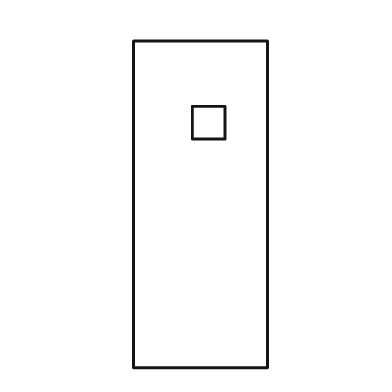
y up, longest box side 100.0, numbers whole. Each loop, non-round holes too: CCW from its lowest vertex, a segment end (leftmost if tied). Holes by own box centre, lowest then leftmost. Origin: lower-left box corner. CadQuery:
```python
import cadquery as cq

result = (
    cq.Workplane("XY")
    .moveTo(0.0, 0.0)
    .lineTo(41.0, 0.0)
    .lineTo(41.0, 100.0)
    .lineTo(0.0, 100.0)
    .close()
    .moveTo(18.0, 70.0)
    .lineTo(28.0, 70.0)
    .lineTo(28.0, 80.0)
    .lineTo(18.0, 80.0)
    .close()
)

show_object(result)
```